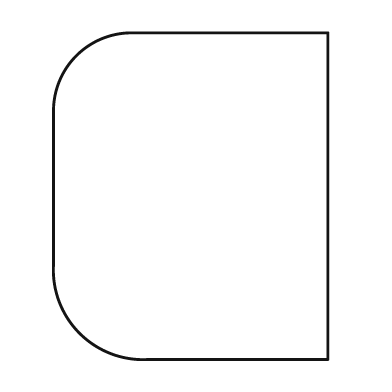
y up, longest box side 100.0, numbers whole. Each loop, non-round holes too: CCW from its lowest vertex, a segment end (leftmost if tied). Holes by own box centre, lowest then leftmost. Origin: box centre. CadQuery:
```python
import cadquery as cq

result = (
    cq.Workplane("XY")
    .moveTo(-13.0, -50.0)
    .lineTo(42.0, -50.0)
    .lineTo(42.0, 50.0)
    .lineTo(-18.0, 50.0)
    .threePointArc((-35.0, 43.0), (-42.0, 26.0))
    .lineTo(-42.0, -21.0)
    .threePointArc((-34.0, -42.0), (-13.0, -50.0))
    .close()
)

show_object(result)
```